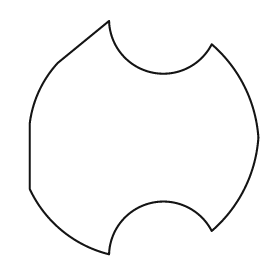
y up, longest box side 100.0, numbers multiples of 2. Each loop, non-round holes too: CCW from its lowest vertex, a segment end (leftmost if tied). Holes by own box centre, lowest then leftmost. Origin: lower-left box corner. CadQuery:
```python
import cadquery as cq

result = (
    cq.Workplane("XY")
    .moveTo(34.0, 0.0)
    .threePointArc((52.0, 22.0), (78.0, 10.0))
    .threePointArc((92.0, 28.0), (98.0, 50.0))
    .threePointArc((92.0, 72.0), (78.0, 90.0))
    .threePointArc((52.0, 78.0), (34.0, 100.0))
    .lineTo(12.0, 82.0)
    .threePointArc((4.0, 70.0), (0.0, 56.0))
    .lineTo(0.0, 28.0)
    .threePointArc((14.0, 10.0), (34.0, 0.0))
    .close()
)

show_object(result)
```